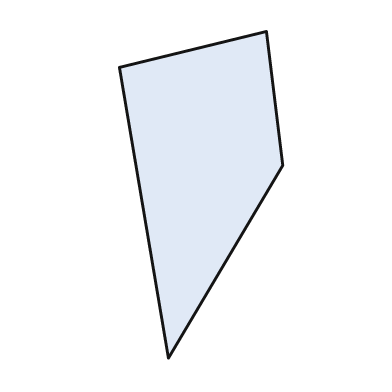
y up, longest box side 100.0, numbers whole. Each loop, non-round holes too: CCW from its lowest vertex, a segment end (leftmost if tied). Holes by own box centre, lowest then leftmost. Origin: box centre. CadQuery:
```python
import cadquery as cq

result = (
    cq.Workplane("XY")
    .moveTo(-10.0, -50.0)
    .lineTo(25.0, 9.0)
    .lineTo(20.0, 50.0)
    .lineTo(-25.0, 39.0)
    .close()
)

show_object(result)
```